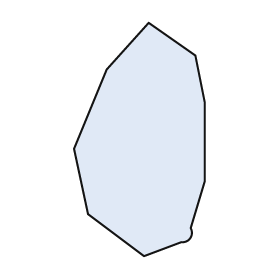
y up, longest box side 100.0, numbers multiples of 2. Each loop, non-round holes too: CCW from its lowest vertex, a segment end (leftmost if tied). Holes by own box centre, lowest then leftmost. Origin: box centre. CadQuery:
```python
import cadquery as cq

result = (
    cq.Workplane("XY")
    .moveTo(2.0, -50.0)
    .lineTo(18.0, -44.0)
    .threePointArc((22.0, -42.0), (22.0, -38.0))
    .lineTo(28.0, -18.0)
    .lineTo(28.0, 16.0)
    .lineTo(24.0, 36.0)
    .lineTo(4.0, 50.0)
    .lineTo(-14.0, 30.0)
    .lineTo(-28.0, -4.0)
    .lineTo(-22.0, -32.0)
    .close()
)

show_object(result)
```